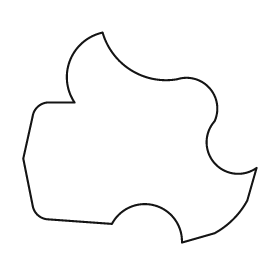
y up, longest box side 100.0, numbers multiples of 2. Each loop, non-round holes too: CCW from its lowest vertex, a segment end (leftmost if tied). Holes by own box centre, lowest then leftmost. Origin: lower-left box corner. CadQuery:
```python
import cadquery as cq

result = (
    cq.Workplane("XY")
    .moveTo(68.0, 0.0)
    .lineTo(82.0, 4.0)
    .threePointArc((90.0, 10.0), (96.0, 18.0))
    .lineTo(100.0, 32.0)
    .threePointArc((82.0, 34.0), (82.0, 52.0))
    .threePointArc((80.0, 66.0), (66.0, 70.0))
    .threePointArc((46.0, 74.0), (34.0, 90.0))
    .threePointArc((20.0, 78.0), (22.0, 60.0))
    .lineTo(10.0, 60.0)
    .threePointArc((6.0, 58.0), (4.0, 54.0))
    .lineTo(0.0, 36.0)
    .lineTo(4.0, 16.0)
    .threePointArc((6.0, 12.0), (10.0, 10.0))
    .lineTo(38.0, 8.0)
    .threePointArc((56.0, 16.0), (68.0, 0.0))
    .close()
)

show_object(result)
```